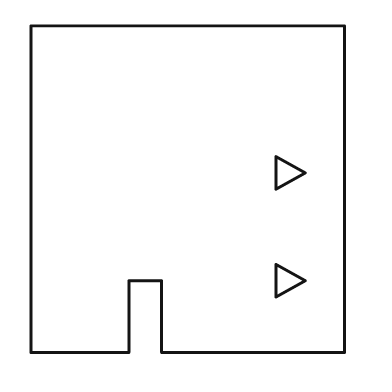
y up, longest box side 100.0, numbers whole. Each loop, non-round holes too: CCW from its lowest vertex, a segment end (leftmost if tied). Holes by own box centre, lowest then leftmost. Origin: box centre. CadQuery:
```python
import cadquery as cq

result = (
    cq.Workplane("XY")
    .moveTo(-48.0, -50.0)
    .lineTo(-18.0, -50.0)
    .lineTo(-18.0, -28.0)
    .lineTo(-8.0, -28.0)
    .lineTo(-8.0, -50.0)
    .lineTo(48.0, -50.0)
    .lineTo(48.0, 50.0)
    .lineTo(-48.0, 50.0)
    .close()
    .moveTo(27.0, -33.0)
    .lineTo(36.0, -28.0)
    .lineTo(27.0, -23.0)
    .close()
    .moveTo(27.0, 0.0)
    .lineTo(36.0, 5.0)
    .lineTo(27.0, 10.0)
    .close()
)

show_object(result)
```